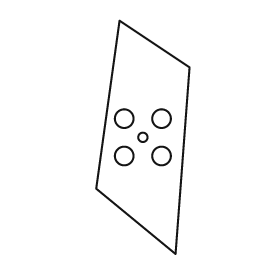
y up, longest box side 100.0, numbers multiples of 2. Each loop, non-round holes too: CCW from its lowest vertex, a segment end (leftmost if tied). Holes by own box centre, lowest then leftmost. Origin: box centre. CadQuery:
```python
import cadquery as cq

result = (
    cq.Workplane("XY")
    .moveTo(14.0, -50.0)
    .lineTo(20.0, 30.0)
    .lineTo(-10.0, 50.0)
    .lineTo(-20.0, -22.0)
    .close()
    .moveTo(-8.0, -8.0)
    .circle(4.0)
    .moveTo(8.0, -8.0)
    .circle(4.0)
    .moveTo(0.0, 0.0)
    .circle(2.0)
    .moveTo(-8.0, 8.0)
    .circle(4.0)
    .moveTo(8.0, 8.0)
    .circle(4.0)
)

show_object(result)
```